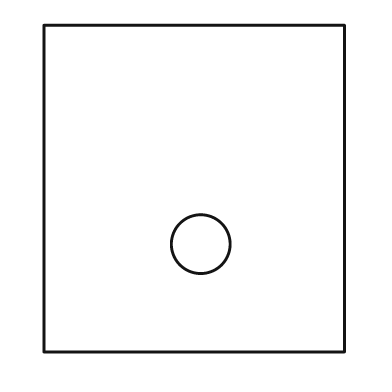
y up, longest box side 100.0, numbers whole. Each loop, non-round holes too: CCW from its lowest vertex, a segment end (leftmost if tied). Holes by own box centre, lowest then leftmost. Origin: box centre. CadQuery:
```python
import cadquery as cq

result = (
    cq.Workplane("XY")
    .moveTo(-46.0, -50.0)
    .lineTo(46.0, -50.0)
    .lineTo(46.0, 50.0)
    .lineTo(-46.0, 50.0)
    .close()
    .moveTo(2.0, -17.0)
    .circle(9.0)
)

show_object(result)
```